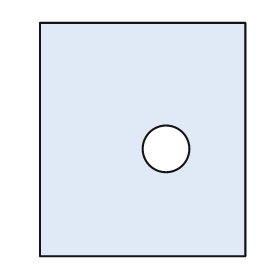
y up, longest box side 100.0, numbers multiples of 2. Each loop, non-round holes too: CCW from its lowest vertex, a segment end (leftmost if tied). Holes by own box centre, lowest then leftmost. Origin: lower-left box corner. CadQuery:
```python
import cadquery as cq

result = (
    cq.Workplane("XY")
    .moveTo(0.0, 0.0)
    .lineTo(88.0, 0.0)
    .lineTo(88.0, 100.0)
    .lineTo(0.0, 100.0)
    .close()
    .moveTo(54.0, 46.0)
    .circle(10.0)
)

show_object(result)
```